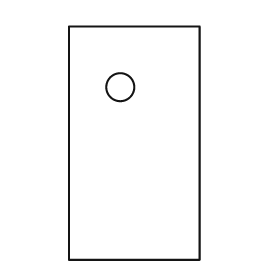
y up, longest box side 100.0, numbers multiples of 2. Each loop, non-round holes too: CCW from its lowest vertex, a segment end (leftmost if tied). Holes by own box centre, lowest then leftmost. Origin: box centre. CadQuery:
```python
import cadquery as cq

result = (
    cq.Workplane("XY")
    .moveTo(-28.0, -50.0)
    .lineTo(28.0, -50.0)
    .lineTo(28.0, 50.0)
    .lineTo(-28.0, 50.0)
    .close()
    .moveTo(-6.0, 24.0)
    .circle(6.0)
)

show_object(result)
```